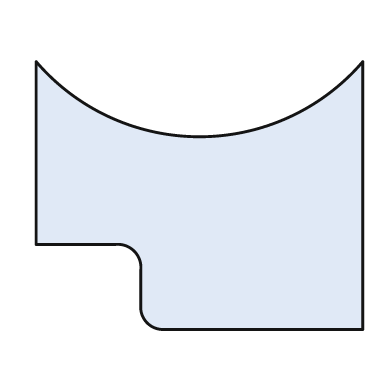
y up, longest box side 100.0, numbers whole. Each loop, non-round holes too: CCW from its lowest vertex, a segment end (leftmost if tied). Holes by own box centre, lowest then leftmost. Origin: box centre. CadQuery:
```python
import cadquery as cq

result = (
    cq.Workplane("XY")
    .moveTo(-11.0, -41.0)
    .lineTo(50.0, -41.0)
    .lineTo(50.0, 41.0)
    .threePointArc((0.0, 18.0), (-50.0, 41.0))
    .lineTo(-50.0, -15.0)
    .lineTo(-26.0, -15.0)
    .threePointArc((-20.0, -17.0), (-18.0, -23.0))
    .lineTo(-18.0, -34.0)
    .threePointArc((-16.0, -39.0), (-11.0, -41.0))
    .close()
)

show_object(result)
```